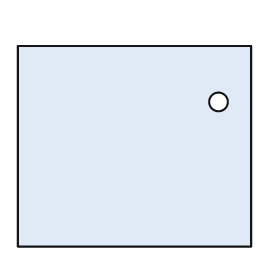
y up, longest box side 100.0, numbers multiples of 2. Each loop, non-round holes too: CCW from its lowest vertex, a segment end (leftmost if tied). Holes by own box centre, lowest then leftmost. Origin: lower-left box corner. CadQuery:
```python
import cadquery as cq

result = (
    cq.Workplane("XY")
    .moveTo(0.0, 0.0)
    .lineTo(100.0, 0.0)
    .lineTo(100.0, 86.0)
    .lineTo(0.0, 86.0)
    .close()
    .moveTo(86.0, 62.0)
    .circle(4.0)
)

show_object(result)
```